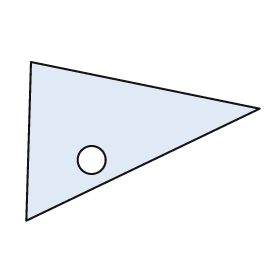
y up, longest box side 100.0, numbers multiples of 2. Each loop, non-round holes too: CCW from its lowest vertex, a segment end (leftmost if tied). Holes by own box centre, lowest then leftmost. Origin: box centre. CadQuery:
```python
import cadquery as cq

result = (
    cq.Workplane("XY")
    .moveTo(-50.0, -34.0)
    .lineTo(50.0, 14.0)
    .lineTo(-48.0, 34.0)
    .close()
    .moveTo(-22.0, -8.0)
    .circle(6.0)
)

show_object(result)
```